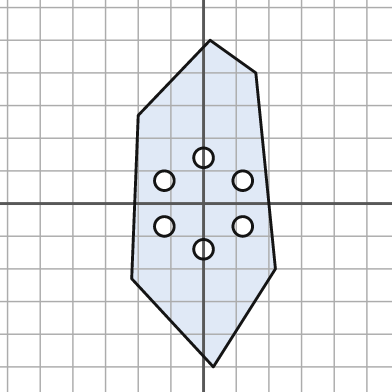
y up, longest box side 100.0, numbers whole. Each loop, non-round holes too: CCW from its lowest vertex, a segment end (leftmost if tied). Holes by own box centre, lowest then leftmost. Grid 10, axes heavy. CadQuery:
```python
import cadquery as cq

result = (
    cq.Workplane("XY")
    .moveTo(3.0, -50.0)
    .lineTo(22.0, -20.0)
    .lineTo(16.0, 40.0)
    .lineTo(2.0, 50.0)
    .lineTo(-20.0, 27.0)
    .lineTo(-22.0, -23.0)
    .close()
    .moveTo(0.0, -14.0)
    .circle(3.0)
    .moveTo(-12.0, -7.0)
    .circle(3.0)
    .moveTo(12.0, -7.0)
    .circle(3.0)
    .moveTo(-12.0, 7.0)
    .circle(3.0)
    .moveTo(12.0, 7.0)
    .circle(3.0)
    .moveTo(0.0, 14.0)
    .circle(3.0)
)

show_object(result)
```